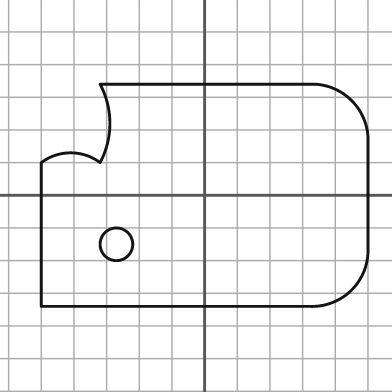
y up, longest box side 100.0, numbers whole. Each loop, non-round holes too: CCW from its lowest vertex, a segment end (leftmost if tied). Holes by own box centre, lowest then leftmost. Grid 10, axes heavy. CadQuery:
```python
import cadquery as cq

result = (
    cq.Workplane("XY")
    .moveTo(-50.0, -34.0)
    .lineTo(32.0, -34.0)
    .threePointArc((45.0, -29.0), (50.0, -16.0))
    .lineTo(50.0, 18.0)
    .threePointArc((45.0, 29.0), (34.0, 34.0))
    .lineTo(-32.0, 34.0)
    .threePointArc((-29.0, 22.0), (-32.0, 10.0))
    .threePointArc((-41.0, 13.0), (-50.0, 10.0))
    .close()
    .moveTo(-27.0, -15.0)
    .circle(5.0)
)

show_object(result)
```